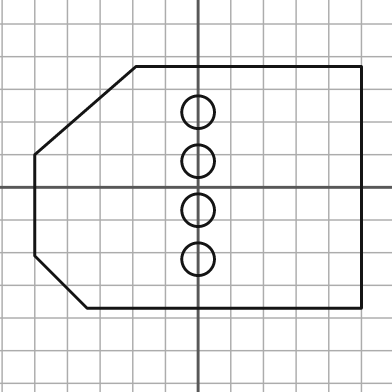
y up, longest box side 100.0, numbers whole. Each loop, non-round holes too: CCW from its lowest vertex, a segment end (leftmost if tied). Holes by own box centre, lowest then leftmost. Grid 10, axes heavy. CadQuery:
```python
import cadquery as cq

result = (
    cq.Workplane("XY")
    .moveTo(-34.0, -37.0)
    .lineTo(50.0, -37.0)
    .lineTo(50.0, 37.0)
    .lineTo(-19.0, 37.0)
    .lineTo(-50.0, 10.0)
    .lineTo(-50.0, -21.0)
    .close()
    .moveTo(0.0, -22.0)
    .circle(5.0)
    .moveTo(0.0, -7.0)
    .circle(5.0)
    .moveTo(0.0, 8.0)
    .circle(5.0)
    .moveTo(0.0, 23.0)
    .circle(5.0)
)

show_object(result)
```